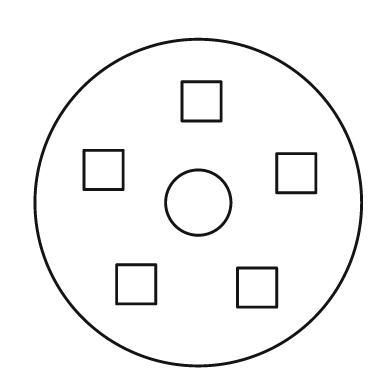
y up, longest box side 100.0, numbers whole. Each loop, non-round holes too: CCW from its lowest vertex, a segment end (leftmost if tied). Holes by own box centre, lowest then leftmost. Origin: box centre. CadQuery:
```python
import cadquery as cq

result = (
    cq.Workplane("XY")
    .moveTo(0.0, 0.0)
    .circle(50.0)
    .moveTo(12.0, -32.0)
    .lineTo(24.0, -32.0)
    .lineTo(24.0, -20.0)
    .lineTo(12.0, -20.0)
    .close()
    .moveTo(-25.0, -31.0)
    .lineTo(-13.0, -31.0)
    .lineTo(-13.0, -19.0)
    .lineTo(-25.0, -19.0)
    .close()
    .moveTo(0.0, 0.0)
    .circle(10.0)
    .moveTo(24.0, 3.0)
    .lineTo(36.0, 3.0)
    .lineTo(36.0, 15.0)
    .lineTo(24.0, 15.0)
    .close()
    .moveTo(-35.0, 4.0)
    .lineTo(-23.0, 4.0)
    .lineTo(-23.0, 16.0)
    .lineTo(-35.0, 16.0)
    .close()
    .moveTo(-5.0, 25.0)
    .lineTo(7.0, 25.0)
    .lineTo(7.0, 37.0)
    .lineTo(-5.0, 37.0)
    .close()
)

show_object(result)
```